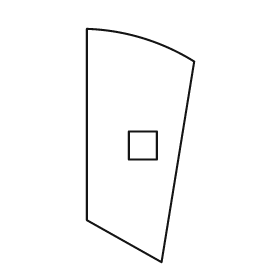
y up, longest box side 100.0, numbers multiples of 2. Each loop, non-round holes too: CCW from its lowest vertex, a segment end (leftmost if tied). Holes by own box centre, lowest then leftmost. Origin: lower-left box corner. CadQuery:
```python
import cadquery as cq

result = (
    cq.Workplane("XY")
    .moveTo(32.0, 0.0)
    .lineTo(46.0, 86.0)
    .threePointArc((24.0, 96.0), (0.0, 100.0))
    .lineTo(0.0, 18.0)
    .close()
    .moveTo(18.0, 44.0)
    .lineTo(30.0, 44.0)
    .lineTo(30.0, 56.0)
    .lineTo(18.0, 56.0)
    .close()
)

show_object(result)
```